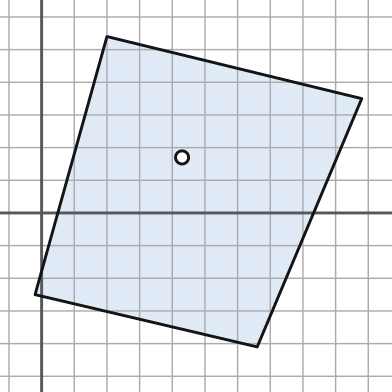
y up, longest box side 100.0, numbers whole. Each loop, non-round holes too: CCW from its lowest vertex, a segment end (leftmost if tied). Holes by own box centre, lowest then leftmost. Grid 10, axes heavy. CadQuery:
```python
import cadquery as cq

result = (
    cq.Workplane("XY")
    .moveTo(66.0, -41.0)
    .lineTo(98.0, 35.0)
    .lineTo(20.0, 54.0)
    .lineTo(-2.0, -25.0)
    .close()
    .moveTo(43.0, 17.0)
    .circle(2.0)
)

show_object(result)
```